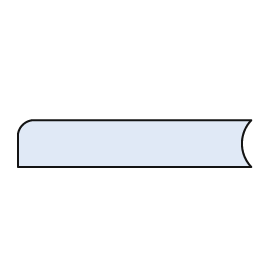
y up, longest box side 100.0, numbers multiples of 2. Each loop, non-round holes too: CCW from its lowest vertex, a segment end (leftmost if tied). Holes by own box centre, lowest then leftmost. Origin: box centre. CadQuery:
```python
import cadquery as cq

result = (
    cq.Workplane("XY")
    .moveTo(-50.0, -10.0)
    .lineTo(50.0, -10.0)
    .threePointArc((46.0, 0.0), (50.0, 10.0))
    .lineTo(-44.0, 10.0)
    .threePointArc((-48.0, 8.0), (-50.0, 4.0))
    .close()
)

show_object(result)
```